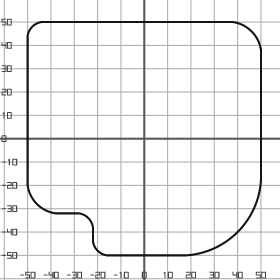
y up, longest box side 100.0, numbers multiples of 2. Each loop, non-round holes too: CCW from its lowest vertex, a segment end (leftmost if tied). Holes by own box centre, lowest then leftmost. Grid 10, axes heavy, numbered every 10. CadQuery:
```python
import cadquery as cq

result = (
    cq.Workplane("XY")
    .moveTo(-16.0, -50.0)
    .lineTo(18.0, -50.0)
    .threePointArc((40.0, -40.0), (50.0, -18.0))
    .lineTo(50.0, 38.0)
    .threePointArc((46.0, 46.0), (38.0, 50.0))
    .lineTo(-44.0, 50.0)
    .threePointArc((-48.0, 48.0), (-50.0, 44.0))
    .lineTo(-50.0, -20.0)
    .threePointArc((-46.0, -28.0), (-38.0, -32.0))
    .lineTo(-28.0, -32.0)
    .threePointArc((-24.0, -34.0), (-22.0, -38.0))
    .lineTo(-22.0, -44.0)
    .threePointArc((-20.0, -48.0), (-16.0, -50.0))
    .close()
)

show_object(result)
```